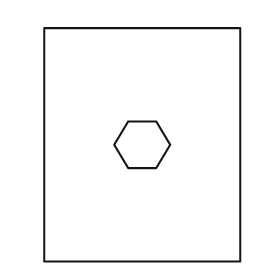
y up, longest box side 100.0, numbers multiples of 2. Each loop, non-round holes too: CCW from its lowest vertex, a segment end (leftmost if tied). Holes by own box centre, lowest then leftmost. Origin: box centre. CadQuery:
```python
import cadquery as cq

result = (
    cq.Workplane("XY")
    .moveTo(-42.0, -50.0)
    .lineTo(42.0, -50.0)
    .lineTo(42.0, 50.0)
    .lineTo(-42.0, 50.0)
    .close()
    .moveTo(-6.0, -10.0)
    .lineTo(6.0, -10.0)
    .lineTo(12.0, 0.0)
    .lineTo(6.0, 10.0)
    .lineTo(-6.0, 10.0)
    .lineTo(-12.0, 0.0)
    .close()
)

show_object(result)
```